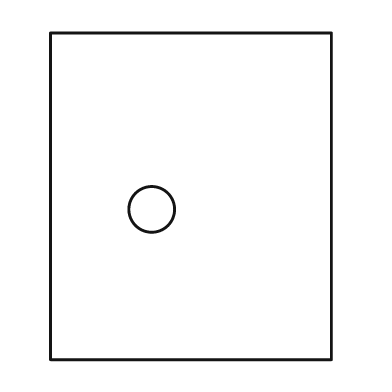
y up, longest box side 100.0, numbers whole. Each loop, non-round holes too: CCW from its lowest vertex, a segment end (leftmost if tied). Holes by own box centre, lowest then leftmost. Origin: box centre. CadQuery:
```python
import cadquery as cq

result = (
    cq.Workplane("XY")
    .moveTo(-43.0, -50.0)
    .lineTo(43.0, -50.0)
    .lineTo(43.0, 50.0)
    .lineTo(-43.0, 50.0)
    .close()
    .moveTo(-12.0, -4.0)
    .circle(7.0)
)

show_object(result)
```